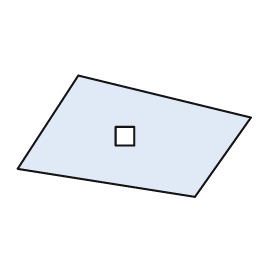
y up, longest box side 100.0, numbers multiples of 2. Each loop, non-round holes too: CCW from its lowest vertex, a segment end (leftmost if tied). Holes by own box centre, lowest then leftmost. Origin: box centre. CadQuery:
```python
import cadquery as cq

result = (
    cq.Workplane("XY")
    .moveTo(26.0, -26.0)
    .lineTo(50.0, 8.0)
    .lineTo(-24.0, 26.0)
    .lineTo(-50.0, -14.0)
    .close()
    .moveTo(-8.0, -4.0)
    .lineTo(0.0, -4.0)
    .lineTo(0.0, 4.0)
    .lineTo(-8.0, 4.0)
    .close()
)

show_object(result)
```